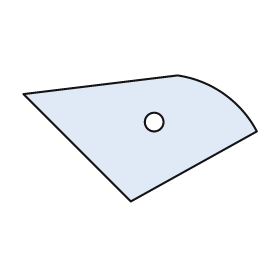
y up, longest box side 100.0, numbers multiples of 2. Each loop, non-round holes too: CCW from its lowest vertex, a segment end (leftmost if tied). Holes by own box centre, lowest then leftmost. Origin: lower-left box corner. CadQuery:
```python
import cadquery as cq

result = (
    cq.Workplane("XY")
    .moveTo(46.0, 0.0)
    .lineTo(100.0, 30.0)
    .threePointArc((86.0, 46.0), (66.0, 54.0))
    .lineTo(0.0, 46.0)
    .close()
    .moveTo(56.0, 34.0)
    .circle(4.0)
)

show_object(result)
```